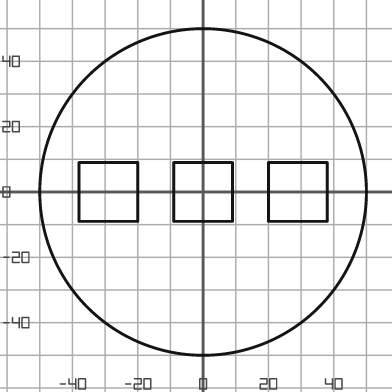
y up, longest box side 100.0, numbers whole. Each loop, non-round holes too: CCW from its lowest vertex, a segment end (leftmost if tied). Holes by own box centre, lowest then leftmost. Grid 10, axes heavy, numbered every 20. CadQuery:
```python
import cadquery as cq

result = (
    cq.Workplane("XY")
    .moveTo(0.0, 0.0)
    .circle(50.0)
    .moveTo(-38.0, -9.0)
    .lineTo(-20.0, -9.0)
    .lineTo(-20.0, 9.0)
    .lineTo(-38.0, 9.0)
    .close()
    .moveTo(-9.0, -9.0)
    .lineTo(9.0, -9.0)
    .lineTo(9.0, 9.0)
    .lineTo(-9.0, 9.0)
    .close()
    .moveTo(20.0, -9.0)
    .lineTo(38.0, -9.0)
    .lineTo(38.0, 9.0)
    .lineTo(20.0, 9.0)
    .close()
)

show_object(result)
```